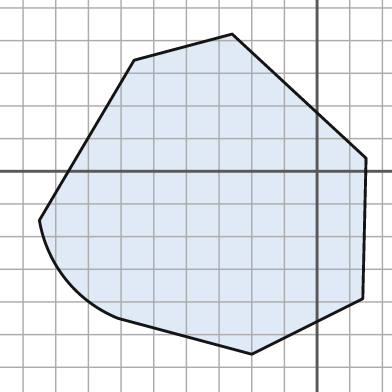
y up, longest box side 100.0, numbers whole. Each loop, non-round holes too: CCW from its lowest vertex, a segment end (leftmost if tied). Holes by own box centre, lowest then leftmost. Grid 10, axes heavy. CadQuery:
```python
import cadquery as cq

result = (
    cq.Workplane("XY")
    .moveTo(-20.0, -56.0)
    .lineTo(14.0, -39.0)
    .lineTo(15.0, 4.0)
    .lineTo(-26.0, 42.0)
    .lineTo(-56.0, 34.0)
    .lineTo(-85.0, -15.0)
    .threePointArc((-77.0, -33.0), (-61.0, -45.0))
    .close()
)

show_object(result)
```